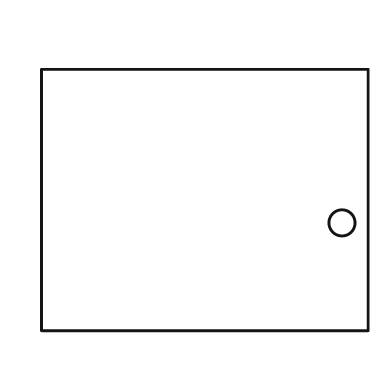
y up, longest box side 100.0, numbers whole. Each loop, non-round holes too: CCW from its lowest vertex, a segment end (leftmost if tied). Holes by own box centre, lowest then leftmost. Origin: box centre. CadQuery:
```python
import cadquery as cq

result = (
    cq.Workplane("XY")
    .moveTo(-50.0, -40.0)
    .lineTo(50.0, -40.0)
    .lineTo(50.0, 40.0)
    .lineTo(-50.0, 40.0)
    .close()
    .moveTo(42.0, -7.0)
    .circle(4.0)
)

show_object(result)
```